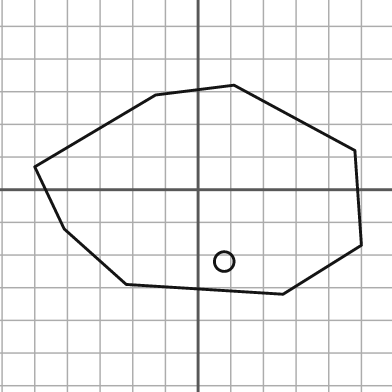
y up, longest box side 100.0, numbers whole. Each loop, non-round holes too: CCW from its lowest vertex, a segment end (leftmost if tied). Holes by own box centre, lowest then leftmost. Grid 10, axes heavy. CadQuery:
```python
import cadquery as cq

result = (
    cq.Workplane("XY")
    .moveTo(26.0, -32.0)
    .lineTo(50.0, -17.0)
    .lineTo(48.0, 12.0)
    .lineTo(11.0, 32.0)
    .lineTo(-13.0, 29.0)
    .lineTo(-50.0, 7.0)
    .lineTo(-41.0, -12.0)
    .lineTo(-22.0, -29.0)
    .close()
    .moveTo(8.0, -22.0)
    .circle(3.0)
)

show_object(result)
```